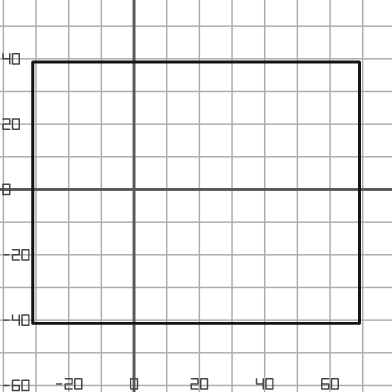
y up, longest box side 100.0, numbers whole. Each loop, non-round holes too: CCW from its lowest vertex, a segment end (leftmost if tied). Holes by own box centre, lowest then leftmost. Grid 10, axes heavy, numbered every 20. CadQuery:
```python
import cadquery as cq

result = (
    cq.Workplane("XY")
    .moveTo(-31.0, -41.0)
    .lineTo(69.0, -41.0)
    .lineTo(69.0, 39.0)
    .lineTo(-31.0, 39.0)
    .close()
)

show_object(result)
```